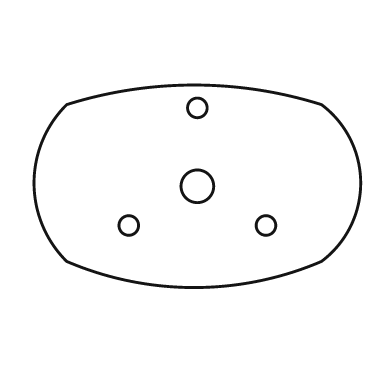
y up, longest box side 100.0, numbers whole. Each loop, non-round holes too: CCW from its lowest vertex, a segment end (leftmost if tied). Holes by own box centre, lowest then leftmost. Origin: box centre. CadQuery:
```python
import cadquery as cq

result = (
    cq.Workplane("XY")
    .moveTo(-40.0, -23.0)
    .threePointArc((-1.0, -31.0), (38.0, -23.0))
    .threePointArc((50.0, 1.0), (38.0, 25.0))
    .threePointArc((-1.0, 31.0), (-40.0, 25.0))
    .threePointArc((-50.0, 1.0), (-40.0, -23.0))
    .close()
    .moveTo(-21.0, -12.0)
    .circle(3.0)
    .moveTo(21.0, -12.0)
    .circle(3.0)
    .moveTo(0.0, 0.0)
    .circle(5.0)
    .moveTo(0.0, 24.0)
    .circle(3.0)
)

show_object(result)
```